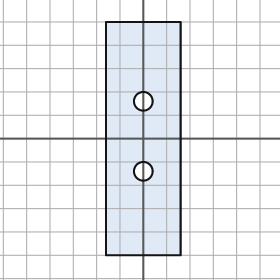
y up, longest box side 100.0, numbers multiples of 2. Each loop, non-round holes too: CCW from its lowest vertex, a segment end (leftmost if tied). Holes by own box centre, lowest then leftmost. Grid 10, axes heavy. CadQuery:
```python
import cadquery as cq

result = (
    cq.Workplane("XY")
    .moveTo(-16.0, -50.0)
    .lineTo(16.0, -50.0)
    .lineTo(16.0, 50.0)
    .lineTo(-16.0, 50.0)
    .close()
    .moveTo(0.0, -14.0)
    .circle(4.0)
    .moveTo(0.0, 16.0)
    .circle(4.0)
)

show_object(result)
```